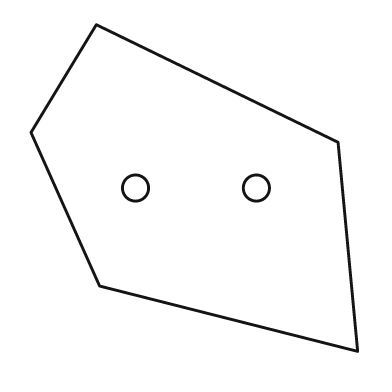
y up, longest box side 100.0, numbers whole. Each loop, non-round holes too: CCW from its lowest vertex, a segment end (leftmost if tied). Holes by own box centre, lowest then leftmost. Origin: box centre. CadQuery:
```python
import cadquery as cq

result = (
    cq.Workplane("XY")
    .moveTo(50.0, -50.0)
    .lineTo(44.0, 14.0)
    .lineTo(-30.0, 50.0)
    .lineTo(-50.0, 17.0)
    .lineTo(-29.0, -30.0)
    .close()
    .moveTo(-18.0, 0.0)
    .circle(4.0)
    .moveTo(19.0, 0.0)
    .circle(4.0)
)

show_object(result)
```